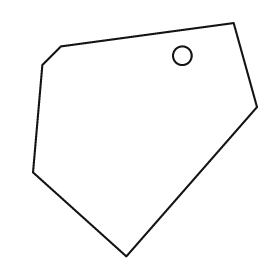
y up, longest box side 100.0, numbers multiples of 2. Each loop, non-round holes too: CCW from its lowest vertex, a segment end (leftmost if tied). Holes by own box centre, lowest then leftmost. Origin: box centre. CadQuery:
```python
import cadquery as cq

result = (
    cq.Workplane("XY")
    .moveTo(-8.0, -50.0)
    .lineTo(48.0, 14.0)
    .lineTo(38.0, 50.0)
    .lineTo(-36.0, 40.0)
    .lineTo(-44.0, 32.0)
    .lineTo(-48.0, -14.0)
    .close()
    .moveTo(16.0, 36.0)
    .circle(4.0)
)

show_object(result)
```